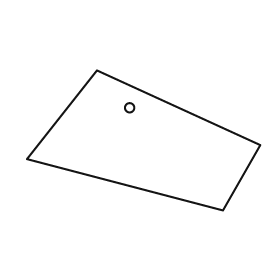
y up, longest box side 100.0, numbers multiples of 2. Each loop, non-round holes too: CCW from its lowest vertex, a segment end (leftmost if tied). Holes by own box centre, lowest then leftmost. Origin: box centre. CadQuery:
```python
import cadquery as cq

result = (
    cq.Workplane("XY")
    .moveTo(34.0, -30.0)
    .lineTo(50.0, -2.0)
    .lineTo(-20.0, 30.0)
    .lineTo(-50.0, -8.0)
    .close()
    .moveTo(-6.0, 14.0)
    .circle(2.0)
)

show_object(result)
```